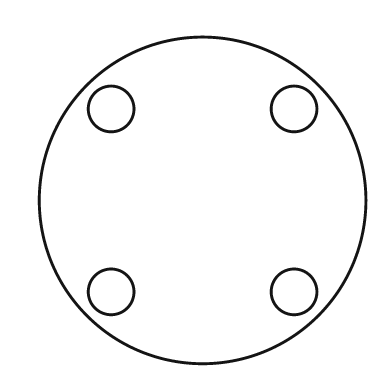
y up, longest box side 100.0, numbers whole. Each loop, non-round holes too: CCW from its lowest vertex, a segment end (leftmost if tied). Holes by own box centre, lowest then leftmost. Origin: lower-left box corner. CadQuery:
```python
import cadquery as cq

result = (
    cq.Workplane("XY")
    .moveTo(50.0, 50.0)
    .circle(50.0)
    .moveTo(22.0, 22.0)
    .circle(7.0)
    .moveTo(78.0, 22.0)
    .circle(7.0)
    .moveTo(22.0, 78.0)
    .circle(7.0)
    .moveTo(78.0, 78.0)
    .circle(7.0)
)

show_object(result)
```